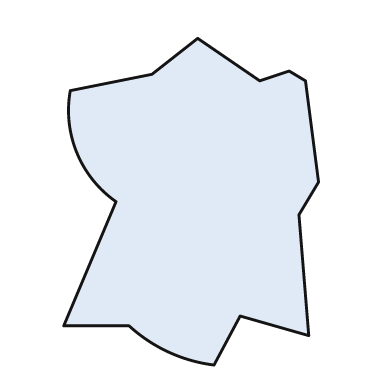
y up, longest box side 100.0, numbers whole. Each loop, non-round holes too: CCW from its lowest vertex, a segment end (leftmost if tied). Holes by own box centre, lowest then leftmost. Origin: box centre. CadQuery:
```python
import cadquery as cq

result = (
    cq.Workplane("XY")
    .moveTo(7.0, -50.0)
    .lineTo(15.0, -35.0)
    .lineTo(36.0, -41.0)
    .lineTo(33.0, -4.0)
    .lineTo(39.0, 6.0)
    .lineTo(35.0, 37.0)
    .lineTo(30.0, 40.0)
    .lineTo(21.0, 37.0)
    .lineTo(2.0, 50.0)
    .lineTo(-12.0, 39.0)
    .lineTo(-37.0, 34.0)
    .threePointArc((-35.0, 15.0), (-23.0, 0.0))
    .lineTo(-39.0, -38.0)
    .lineTo(-19.0, -38.0)
    .threePointArc((-7.0, -46.0), (7.0, -50.0))
    .close()
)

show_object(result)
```